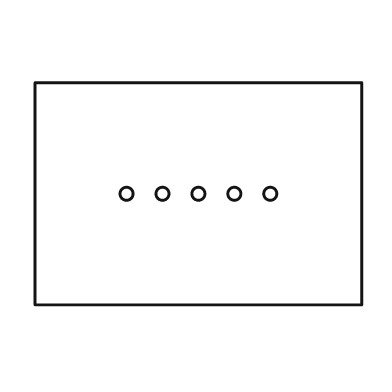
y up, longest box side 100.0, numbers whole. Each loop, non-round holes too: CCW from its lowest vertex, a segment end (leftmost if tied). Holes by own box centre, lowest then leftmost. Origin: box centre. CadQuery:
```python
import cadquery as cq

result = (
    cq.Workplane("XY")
    .moveTo(-50.0, -34.0)
    .lineTo(50.0, -34.0)
    .lineTo(50.0, 34.0)
    .lineTo(-50.0, 34.0)
    .close()
    .moveTo(-22.0, 0.0)
    .circle(2.0)
    .moveTo(-11.0, 0.0)
    .circle(2.0)
    .moveTo(0.0, 0.0)
    .circle(2.0)
    .moveTo(11.0, 0.0)
    .circle(2.0)
    .moveTo(22.0, 0.0)
    .circle(2.0)
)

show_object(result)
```